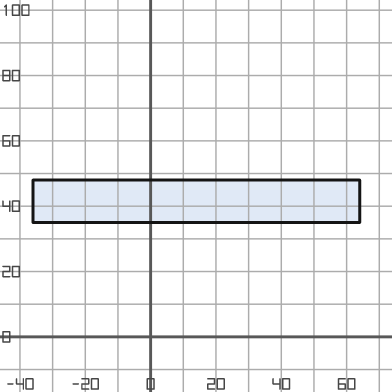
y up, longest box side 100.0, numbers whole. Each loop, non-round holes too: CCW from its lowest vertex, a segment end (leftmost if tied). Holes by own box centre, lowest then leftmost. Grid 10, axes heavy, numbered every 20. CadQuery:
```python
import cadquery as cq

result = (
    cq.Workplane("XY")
    .moveTo(-36.0, 35.0)
    .lineTo(64.0, 35.0)
    .lineTo(64.0, 48.0)
    .lineTo(-36.0, 48.0)
    .close()
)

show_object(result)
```